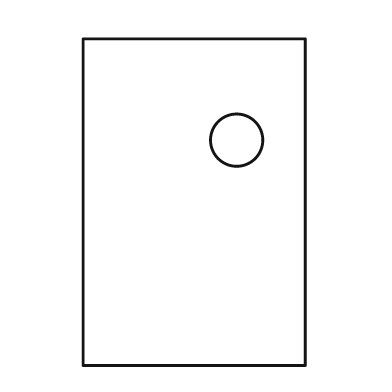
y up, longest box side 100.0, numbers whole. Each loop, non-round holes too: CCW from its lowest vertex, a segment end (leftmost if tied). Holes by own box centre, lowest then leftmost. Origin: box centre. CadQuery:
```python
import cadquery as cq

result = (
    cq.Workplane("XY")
    .moveTo(-34.0, -50.0)
    .lineTo(34.0, -50.0)
    .lineTo(34.0, 50.0)
    .lineTo(-34.0, 50.0)
    .close()
    .moveTo(13.0, 19.0)
    .circle(8.0)
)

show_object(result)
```